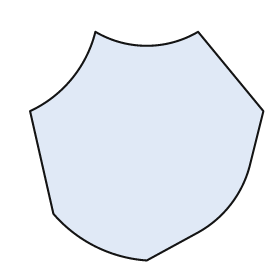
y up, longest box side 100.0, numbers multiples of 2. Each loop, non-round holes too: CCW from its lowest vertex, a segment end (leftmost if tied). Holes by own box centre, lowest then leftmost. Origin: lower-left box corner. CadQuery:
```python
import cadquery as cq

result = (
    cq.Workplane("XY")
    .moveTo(50.0, 0.0)
    .lineTo(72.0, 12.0)
    .threePointArc((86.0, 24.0), (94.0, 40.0))
    .lineTo(100.0, 64.0)
    .lineTo(72.0, 98.0)
    .threePointArc((50.0, 92.0), (28.0, 98.0))
    .threePointArc((18.0, 78.0), (0.0, 64.0))
    .lineTo(10.0, 20.0)
    .threePointArc((28.0, 6.0), (50.0, 0.0))
    .close()
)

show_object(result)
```